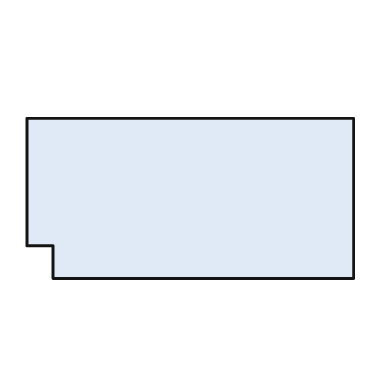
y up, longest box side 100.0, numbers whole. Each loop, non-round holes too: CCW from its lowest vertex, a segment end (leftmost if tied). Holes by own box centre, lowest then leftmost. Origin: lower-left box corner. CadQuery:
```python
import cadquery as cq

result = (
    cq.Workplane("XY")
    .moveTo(8.0, 0.0)
    .lineTo(100.0, 0.0)
    .lineTo(100.0, 49.0)
    .lineTo(0.0, 49.0)
    .lineTo(0.0, 10.0)
    .lineTo(8.0, 10.0)
    .close()
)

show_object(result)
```